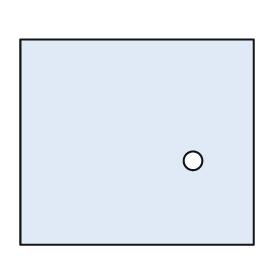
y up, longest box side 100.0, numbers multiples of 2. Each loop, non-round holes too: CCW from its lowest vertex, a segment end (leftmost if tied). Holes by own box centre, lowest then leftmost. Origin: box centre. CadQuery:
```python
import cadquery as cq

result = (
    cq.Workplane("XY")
    .moveTo(-50.0, -44.0)
    .lineTo(50.0, -44.0)
    .lineTo(50.0, 44.0)
    .lineTo(-50.0, 44.0)
    .close()
    .moveTo(24.0, -8.0)
    .circle(4.0)
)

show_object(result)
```